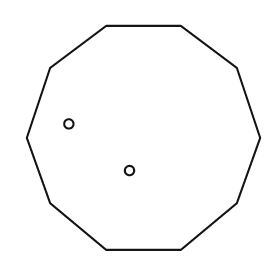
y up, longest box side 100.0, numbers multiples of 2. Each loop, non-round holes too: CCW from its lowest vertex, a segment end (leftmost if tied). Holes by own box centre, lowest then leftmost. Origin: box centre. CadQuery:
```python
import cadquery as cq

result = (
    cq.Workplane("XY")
    .moveTo(-16.0, -48.0)
    .lineTo(16.0, -48.0)
    .lineTo(40.0, -28.0)
    .lineTo(50.0, 0.0)
    .lineTo(40.0, 30.0)
    .lineTo(16.0, 48.0)
    .lineTo(-16.0, 48.0)
    .lineTo(-40.0, 30.0)
    .lineTo(-50.0, 0.0)
    .lineTo(-40.0, -28.0)
    .close()
    .moveTo(-6.0, -14.0)
    .circle(2.0)
    .moveTo(-32.0, 6.0)
    .circle(2.0)
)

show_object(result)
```